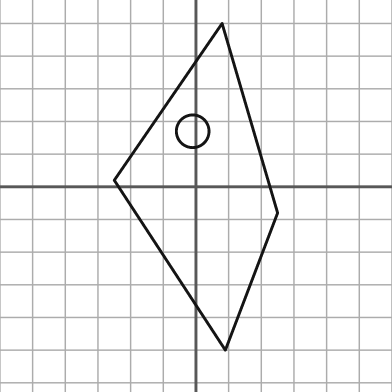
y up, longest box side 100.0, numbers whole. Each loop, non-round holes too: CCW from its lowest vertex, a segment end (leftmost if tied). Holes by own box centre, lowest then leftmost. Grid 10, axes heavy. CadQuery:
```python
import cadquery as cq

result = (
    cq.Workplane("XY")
    .moveTo(9.0, -50.0)
    .lineTo(25.0, -8.0)
    .lineTo(8.0, 50.0)
    .lineTo(-25.0, 2.0)
    .close()
    .moveTo(-1.0, 17.0)
    .circle(5.0)
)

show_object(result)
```